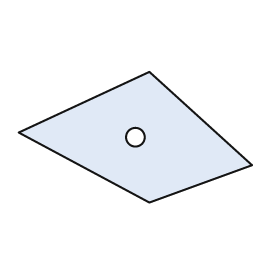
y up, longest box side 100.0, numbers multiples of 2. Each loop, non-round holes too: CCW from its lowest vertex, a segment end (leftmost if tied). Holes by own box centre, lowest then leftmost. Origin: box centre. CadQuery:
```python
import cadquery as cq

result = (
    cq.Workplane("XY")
    .moveTo(6.0, -28.0)
    .lineTo(50.0, -12.0)
    .lineTo(6.0, 28.0)
    .lineTo(-50.0, 2.0)
    .close()
    .moveTo(0.0, 0.0)
    .circle(4.0)
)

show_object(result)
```